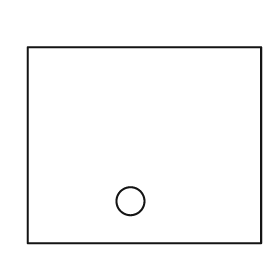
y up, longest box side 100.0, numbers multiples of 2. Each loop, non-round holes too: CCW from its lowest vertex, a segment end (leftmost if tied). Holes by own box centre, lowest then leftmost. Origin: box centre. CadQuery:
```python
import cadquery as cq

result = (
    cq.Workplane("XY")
    .moveTo(-50.0, -42.0)
    .lineTo(50.0, -42.0)
    .lineTo(50.0, 42.0)
    .lineTo(-50.0, 42.0)
    .close()
    .moveTo(-6.0, -24.0)
    .circle(6.0)
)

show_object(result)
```